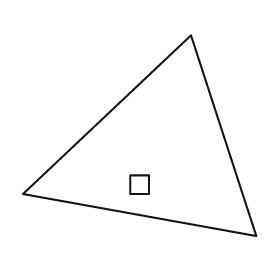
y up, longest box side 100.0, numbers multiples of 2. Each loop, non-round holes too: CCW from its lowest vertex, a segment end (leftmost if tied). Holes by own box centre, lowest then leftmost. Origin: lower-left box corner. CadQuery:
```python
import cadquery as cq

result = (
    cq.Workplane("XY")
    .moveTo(100.0, 0.0)
    .lineTo(72.0, 86.0)
    .lineTo(0.0, 18.0)
    .close()
    .moveTo(46.0, 18.0)
    .lineTo(54.0, 18.0)
    .lineTo(54.0, 26.0)
    .lineTo(46.0, 26.0)
    .close()
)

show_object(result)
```